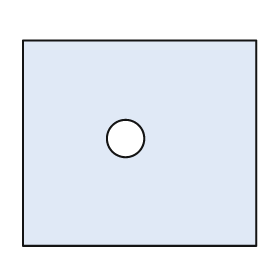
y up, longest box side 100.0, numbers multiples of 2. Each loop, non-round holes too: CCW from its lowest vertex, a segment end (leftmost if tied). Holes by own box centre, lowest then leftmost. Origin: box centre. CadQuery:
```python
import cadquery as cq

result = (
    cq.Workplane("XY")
    .moveTo(-50.0, -44.0)
    .lineTo(50.0, -44.0)
    .lineTo(50.0, 44.0)
    .lineTo(-50.0, 44.0)
    .close()
    .moveTo(-6.0, 2.0)
    .circle(8.0)
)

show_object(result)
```